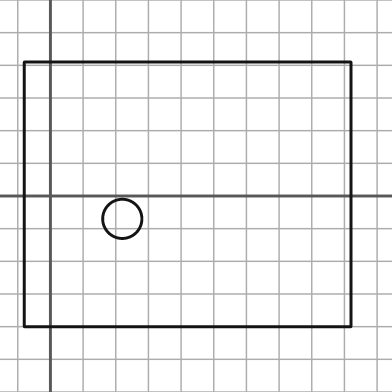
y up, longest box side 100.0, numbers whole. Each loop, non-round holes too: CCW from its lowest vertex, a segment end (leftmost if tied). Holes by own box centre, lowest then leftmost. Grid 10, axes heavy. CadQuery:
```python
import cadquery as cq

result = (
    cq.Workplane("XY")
    .moveTo(-8.0, -40.0)
    .lineTo(92.0, -40.0)
    .lineTo(92.0, 41.0)
    .lineTo(-8.0, 41.0)
    .close()
    .moveTo(22.0, -7.0)
    .circle(6.0)
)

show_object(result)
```